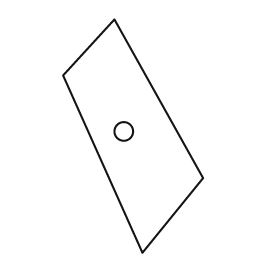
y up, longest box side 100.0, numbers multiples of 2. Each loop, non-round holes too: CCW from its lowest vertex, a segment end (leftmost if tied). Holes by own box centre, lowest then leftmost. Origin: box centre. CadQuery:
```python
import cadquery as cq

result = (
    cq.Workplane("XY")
    .moveTo(4.0, -50.0)
    .lineTo(30.0, -18.0)
    .lineTo(-8.0, 50.0)
    .lineTo(-30.0, 26.0)
    .close()
    .moveTo(-4.0, 2.0)
    .circle(4.0)
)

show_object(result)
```